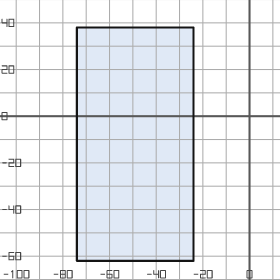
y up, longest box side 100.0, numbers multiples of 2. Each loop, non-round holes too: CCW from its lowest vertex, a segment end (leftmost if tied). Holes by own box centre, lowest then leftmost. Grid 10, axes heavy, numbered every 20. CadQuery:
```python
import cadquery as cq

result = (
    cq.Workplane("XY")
    .moveTo(-74.0, -62.0)
    .lineTo(-24.0, -62.0)
    .lineTo(-24.0, 38.0)
    .lineTo(-74.0, 38.0)
    .close()
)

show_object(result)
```